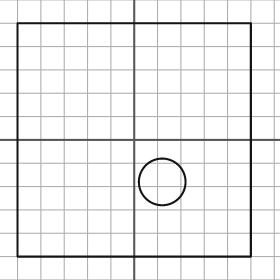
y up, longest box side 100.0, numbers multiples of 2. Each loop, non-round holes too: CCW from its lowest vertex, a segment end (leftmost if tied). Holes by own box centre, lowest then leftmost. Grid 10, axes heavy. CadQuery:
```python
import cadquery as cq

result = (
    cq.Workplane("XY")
    .moveTo(-50.0, -50.0)
    .lineTo(50.0, -50.0)
    .lineTo(50.0, 50.0)
    .lineTo(-50.0, 50.0)
    .close()
    .moveTo(12.0, -18.0)
    .circle(10.0)
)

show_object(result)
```